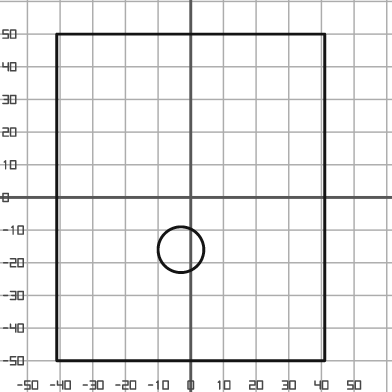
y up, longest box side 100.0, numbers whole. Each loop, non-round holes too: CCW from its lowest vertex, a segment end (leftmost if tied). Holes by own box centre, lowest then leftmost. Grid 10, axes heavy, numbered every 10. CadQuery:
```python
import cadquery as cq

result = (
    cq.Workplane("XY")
    .moveTo(-41.0, -50.0)
    .lineTo(41.0, -50.0)
    .lineTo(41.0, 50.0)
    .lineTo(-41.0, 50.0)
    .close()
    .moveTo(-3.0, -16.0)
    .circle(7.0)
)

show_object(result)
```